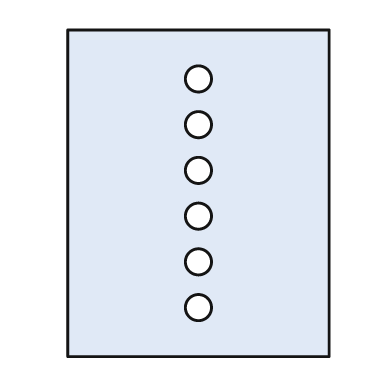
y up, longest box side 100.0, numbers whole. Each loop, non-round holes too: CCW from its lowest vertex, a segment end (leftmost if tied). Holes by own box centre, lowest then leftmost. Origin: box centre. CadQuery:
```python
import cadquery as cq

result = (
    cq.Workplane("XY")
    .moveTo(-40.0, -50.0)
    .lineTo(40.0, -50.0)
    .lineTo(40.0, 50.0)
    .lineTo(-40.0, 50.0)
    .close()
    .moveTo(0.0, -35.0)
    .circle(4.0)
    .moveTo(0.0, -21.0)
    .circle(4.0)
    .moveTo(0.0, -7.0)
    .circle(4.0)
    .moveTo(0.0, 7.0)
    .circle(4.0)
    .moveTo(0.0, 21.0)
    .circle(4.0)
    .moveTo(0.0, 35.0)
    .circle(4.0)
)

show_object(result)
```